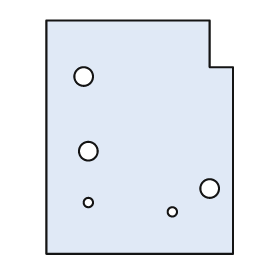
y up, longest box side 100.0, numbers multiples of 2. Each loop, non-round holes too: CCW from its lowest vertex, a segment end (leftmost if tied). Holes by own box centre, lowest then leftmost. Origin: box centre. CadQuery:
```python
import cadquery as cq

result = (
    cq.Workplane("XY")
    .moveTo(-40.0, -50.0)
    .lineTo(40.0, -50.0)
    .lineTo(40.0, 30.0)
    .lineTo(30.0, 30.0)
    .lineTo(30.0, 50.0)
    .lineTo(-40.0, 50.0)
    .close()
    .moveTo(14.0, -32.0)
    .circle(2.0)
    .moveTo(-22.0, -28.0)
    .circle(2.0)
    .moveTo(30.0, -22.0)
    .circle(4.0)
    .moveTo(-22.0, -6.0)
    .circle(4.0)
    .moveTo(-24.0, 26.0)
    .circle(4.0)
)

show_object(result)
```